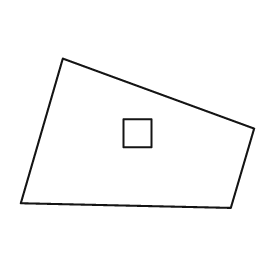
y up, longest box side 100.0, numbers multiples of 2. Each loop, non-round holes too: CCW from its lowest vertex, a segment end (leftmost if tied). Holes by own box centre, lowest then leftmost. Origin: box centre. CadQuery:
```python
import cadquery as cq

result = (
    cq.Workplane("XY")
    .moveTo(40.0, -32.0)
    .lineTo(50.0, 2.0)
    .lineTo(-32.0, 32.0)
    .lineTo(-50.0, -30.0)
    .close()
    .moveTo(-6.0, -6.0)
    .lineTo(6.0, -6.0)
    .lineTo(6.0, 6.0)
    .lineTo(-6.0, 6.0)
    .close()
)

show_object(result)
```